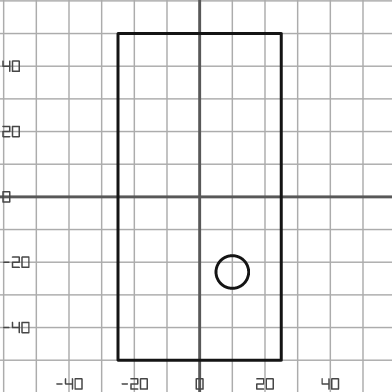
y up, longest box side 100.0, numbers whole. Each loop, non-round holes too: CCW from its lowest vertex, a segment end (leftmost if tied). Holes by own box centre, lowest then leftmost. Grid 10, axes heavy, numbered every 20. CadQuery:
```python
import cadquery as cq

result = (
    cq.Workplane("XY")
    .moveTo(-25.0, -50.0)
    .lineTo(25.0, -50.0)
    .lineTo(25.0, 50.0)
    .lineTo(-25.0, 50.0)
    .close()
    .moveTo(10.0, -23.0)
    .circle(5.0)
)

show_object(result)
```